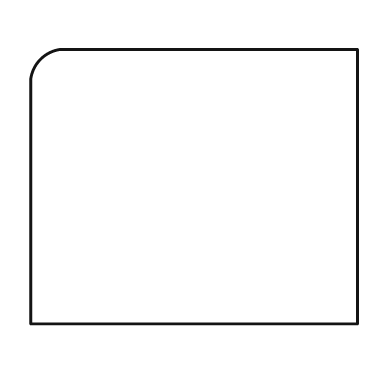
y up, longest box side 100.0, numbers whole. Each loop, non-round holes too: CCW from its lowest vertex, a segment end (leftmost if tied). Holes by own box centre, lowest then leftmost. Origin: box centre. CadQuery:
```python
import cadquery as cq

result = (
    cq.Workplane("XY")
    .moveTo(-50.0, -42.0)
    .lineTo(50.0, -42.0)
    .lineTo(50.0, 42.0)
    .lineTo(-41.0, 42.0)
    .threePointArc((-47.0, 39.0), (-50.0, 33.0))
    .close()
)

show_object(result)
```